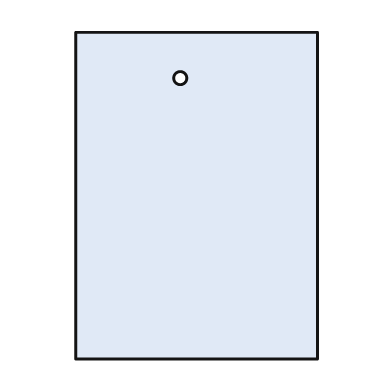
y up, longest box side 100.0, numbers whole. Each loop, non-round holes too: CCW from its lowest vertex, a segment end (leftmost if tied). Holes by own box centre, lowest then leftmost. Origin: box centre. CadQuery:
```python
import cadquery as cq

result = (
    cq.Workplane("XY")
    .moveTo(-37.0, -50.0)
    .lineTo(37.0, -50.0)
    .lineTo(37.0, 50.0)
    .lineTo(-37.0, 50.0)
    .close()
    .moveTo(-5.0, 36.0)
    .circle(2.0)
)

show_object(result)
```